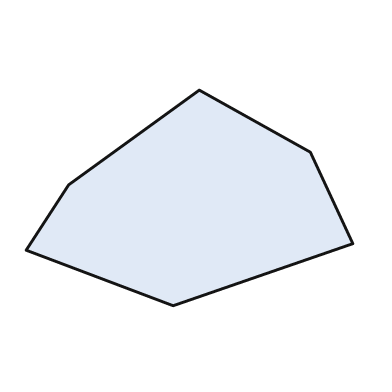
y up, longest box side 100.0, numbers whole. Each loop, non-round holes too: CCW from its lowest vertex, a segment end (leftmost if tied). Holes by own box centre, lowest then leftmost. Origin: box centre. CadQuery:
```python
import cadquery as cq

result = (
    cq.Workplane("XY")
    .moveTo(-5.0, -33.0)
    .lineTo(50.0, -14.0)
    .lineTo(37.0, 14.0)
    .lineTo(3.0, 33.0)
    .lineTo(-37.0, 4.0)
    .lineTo(-50.0, -16.0)
    .close()
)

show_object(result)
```